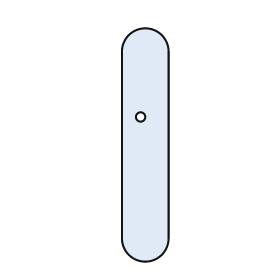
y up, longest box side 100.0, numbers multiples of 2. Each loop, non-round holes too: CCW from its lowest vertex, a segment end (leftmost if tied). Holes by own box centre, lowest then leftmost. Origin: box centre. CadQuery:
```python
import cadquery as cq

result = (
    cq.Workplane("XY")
    .moveTo(-10.0, -40.0)
    .threePointArc((0.0, -50.0), (10.0, -40.0))
    .lineTo(10.0, 40.0)
    .threePointArc((0.0, 50.0), (-10.0, 40.0))
    .close()
    .moveTo(-2.0, 12.0)
    .circle(2.0)
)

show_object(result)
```